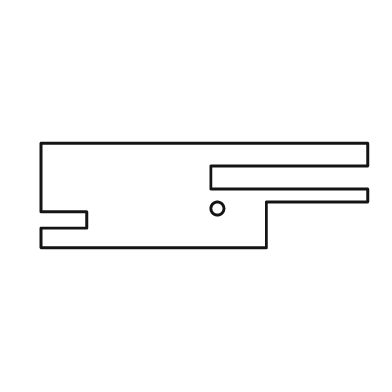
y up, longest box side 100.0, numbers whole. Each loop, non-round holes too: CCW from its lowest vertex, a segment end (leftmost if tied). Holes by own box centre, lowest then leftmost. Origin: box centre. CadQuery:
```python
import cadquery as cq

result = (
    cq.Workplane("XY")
    .moveTo(-50.0, -16.0)
    .lineTo(19.0, -16.0)
    .lineTo(19.0, -2.0)
    .lineTo(50.0, -2.0)
    .lineTo(50.0, 2.0)
    .lineTo(2.0, 2.0)
    .lineTo(2.0, 9.0)
    .lineTo(50.0, 9.0)
    .lineTo(50.0, 16.0)
    .lineTo(-50.0, 16.0)
    .lineTo(-50.0, -5.0)
    .lineTo(-36.0, -5.0)
    .lineTo(-36.0, -10.0)
    .lineTo(-50.0, -10.0)
    .close()
    .moveTo(4.0, -4.0)
    .circle(2.0)
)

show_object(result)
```